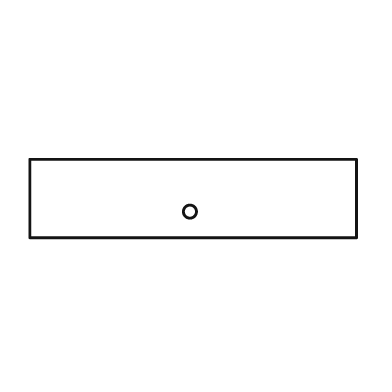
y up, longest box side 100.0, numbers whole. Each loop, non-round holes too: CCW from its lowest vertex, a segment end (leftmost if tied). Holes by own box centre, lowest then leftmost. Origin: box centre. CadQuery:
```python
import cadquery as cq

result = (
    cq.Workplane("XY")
    .moveTo(-50.0, -12.0)
    .lineTo(50.0, -12.0)
    .lineTo(50.0, 12.0)
    .lineTo(-50.0, 12.0)
    .close()
    .moveTo(-1.0, -4.0)
    .circle(2.0)
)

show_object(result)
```